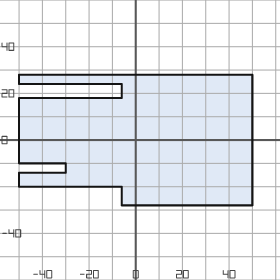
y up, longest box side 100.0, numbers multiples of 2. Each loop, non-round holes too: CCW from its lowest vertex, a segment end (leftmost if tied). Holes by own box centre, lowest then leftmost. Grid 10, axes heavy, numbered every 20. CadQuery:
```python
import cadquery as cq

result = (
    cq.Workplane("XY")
    .moveTo(-6.0, -28.0)
    .lineTo(50.0, -28.0)
    .lineTo(50.0, 28.0)
    .lineTo(-50.0, 28.0)
    .lineTo(-50.0, 24.0)
    .lineTo(-6.0, 24.0)
    .lineTo(-6.0, 18.0)
    .lineTo(-50.0, 18.0)
    .lineTo(-50.0, -10.0)
    .lineTo(-30.0, -10.0)
    .lineTo(-30.0, -14.0)
    .lineTo(-50.0, -14.0)
    .lineTo(-50.0, -20.0)
    .lineTo(-6.0, -20.0)
    .close()
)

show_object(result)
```